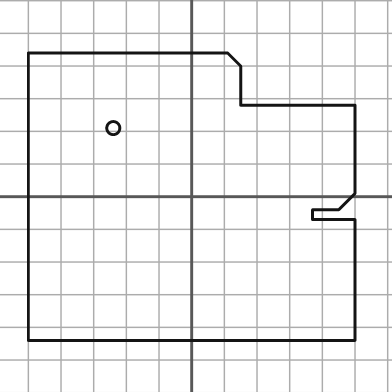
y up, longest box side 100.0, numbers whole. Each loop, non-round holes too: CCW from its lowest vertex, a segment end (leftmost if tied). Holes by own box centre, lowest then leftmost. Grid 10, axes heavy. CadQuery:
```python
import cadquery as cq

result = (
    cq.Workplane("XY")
    .moveTo(-50.0, -44.0)
    .lineTo(50.0, -44.0)
    .lineTo(50.0, -7.0)
    .lineTo(37.0, -7.0)
    .lineTo(37.0, -4.0)
    .lineTo(45.0, -4.0)
    .lineTo(50.0, 1.0)
    .lineTo(50.0, 28.0)
    .lineTo(15.0, 28.0)
    .lineTo(15.0, 40.0)
    .lineTo(11.0, 44.0)
    .lineTo(-50.0, 44.0)
    .close()
    .moveTo(-24.0, 21.0)
    .circle(2.0)
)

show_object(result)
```